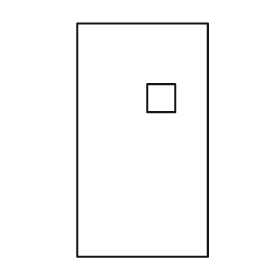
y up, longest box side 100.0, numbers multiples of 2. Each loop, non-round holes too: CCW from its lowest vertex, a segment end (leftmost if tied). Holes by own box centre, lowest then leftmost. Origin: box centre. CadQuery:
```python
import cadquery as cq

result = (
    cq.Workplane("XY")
    .moveTo(-28.0, -50.0)
    .lineTo(28.0, -50.0)
    .lineTo(28.0, 50.0)
    .lineTo(-28.0, 50.0)
    .close()
    .moveTo(2.0, 12.0)
    .lineTo(14.0, 12.0)
    .lineTo(14.0, 24.0)
    .lineTo(2.0, 24.0)
    .close()
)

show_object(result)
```